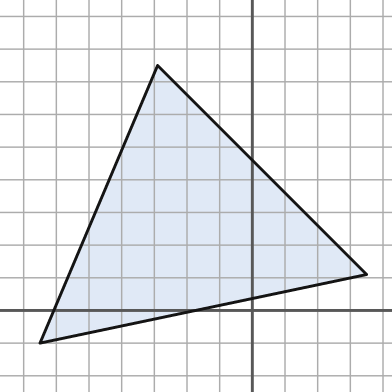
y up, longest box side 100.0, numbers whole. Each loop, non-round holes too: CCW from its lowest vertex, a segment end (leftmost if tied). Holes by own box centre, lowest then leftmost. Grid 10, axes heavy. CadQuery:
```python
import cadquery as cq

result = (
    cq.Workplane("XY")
    .moveTo(-65.0, -10.0)
    .lineTo(35.0, 11.0)
    .lineTo(-29.0, 75.0)
    .close()
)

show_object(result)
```